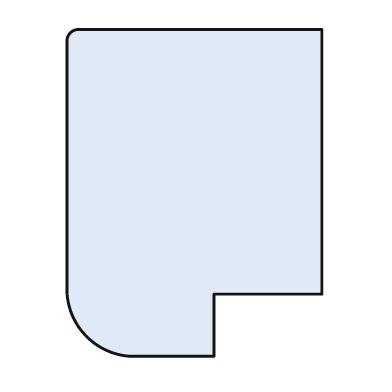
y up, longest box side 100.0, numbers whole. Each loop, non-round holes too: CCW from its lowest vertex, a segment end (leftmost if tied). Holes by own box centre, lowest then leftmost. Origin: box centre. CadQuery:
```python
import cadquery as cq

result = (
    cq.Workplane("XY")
    .moveTo(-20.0, -50.0)
    .lineTo(6.0, -50.0)
    .lineTo(6.0, -31.0)
    .lineTo(39.0, -31.0)
    .lineTo(39.0, 50.0)
    .lineTo(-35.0, 50.0)
    .threePointArc((-38.0, 49.0), (-39.0, 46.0))
    .lineTo(-39.0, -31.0)
    .threePointArc((-33.0, -44.0), (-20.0, -50.0))
    .close()
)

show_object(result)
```